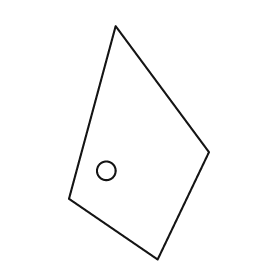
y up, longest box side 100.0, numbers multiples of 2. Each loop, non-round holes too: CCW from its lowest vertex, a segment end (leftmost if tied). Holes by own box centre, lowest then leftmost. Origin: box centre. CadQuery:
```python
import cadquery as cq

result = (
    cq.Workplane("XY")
    .moveTo(8.0, -50.0)
    .lineTo(30.0, -4.0)
    .lineTo(-10.0, 50.0)
    .lineTo(-30.0, -24.0)
    .close()
    .moveTo(-14.0, -12.0)
    .circle(4.0)
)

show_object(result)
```